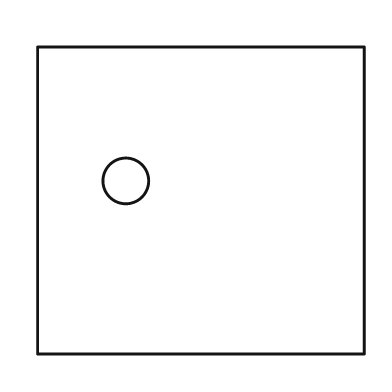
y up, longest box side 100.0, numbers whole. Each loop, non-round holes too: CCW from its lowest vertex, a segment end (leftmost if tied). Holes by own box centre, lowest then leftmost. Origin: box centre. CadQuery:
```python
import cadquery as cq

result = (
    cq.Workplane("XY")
    .moveTo(-50.0, -47.0)
    .lineTo(50.0, -47.0)
    .lineTo(50.0, 47.0)
    .lineTo(-50.0, 47.0)
    .close()
    .moveTo(-23.0, 6.0)
    .circle(7.0)
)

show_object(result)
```